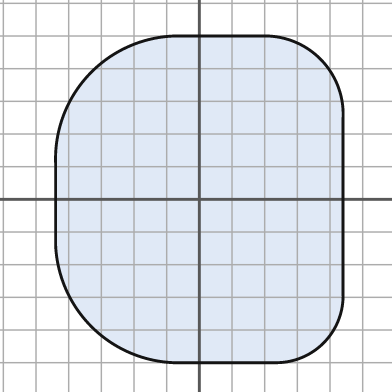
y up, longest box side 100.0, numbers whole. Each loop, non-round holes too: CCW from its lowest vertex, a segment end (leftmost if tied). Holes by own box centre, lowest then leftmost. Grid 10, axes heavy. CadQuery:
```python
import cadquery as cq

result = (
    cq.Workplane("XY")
    .moveTo(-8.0, -50.0)
    .lineTo(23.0, -50.0)
    .threePointArc((38.0, -44.0), (44.0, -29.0))
    .lineTo(44.0, 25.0)
    .threePointArc((37.0, 43.0), (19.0, 50.0))
    .lineTo(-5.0, 50.0)
    .threePointArc((-33.0, 39.0), (-44.0, 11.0))
    .lineTo(-44.0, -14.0)
    .threePointArc((-33.0, -39.0), (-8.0, -50.0))
    .close()
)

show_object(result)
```